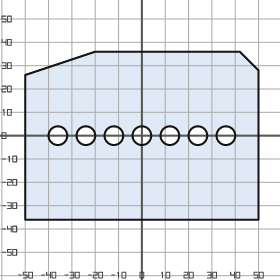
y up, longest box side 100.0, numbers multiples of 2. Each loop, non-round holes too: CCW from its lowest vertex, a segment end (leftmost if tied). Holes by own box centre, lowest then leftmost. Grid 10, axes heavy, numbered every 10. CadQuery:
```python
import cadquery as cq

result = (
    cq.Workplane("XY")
    .moveTo(-50.0, -36.0)
    .lineTo(50.0, -36.0)
    .lineTo(50.0, 28.0)
    .lineTo(42.0, 36.0)
    .lineTo(-20.0, 36.0)
    .lineTo(-50.0, 26.0)
    .close()
    .moveTo(-36.0, 0.0)
    .circle(4.0)
    .moveTo(-24.0, 0.0)
    .circle(4.0)
    .moveTo(-12.0, 0.0)
    .circle(4.0)
    .moveTo(0.0, 0.0)
    .circle(4.0)
    .moveTo(12.0, 0.0)
    .circle(4.0)
    .moveTo(24.0, 0.0)
    .circle(4.0)
    .moveTo(36.0, 0.0)
    .circle(4.0)
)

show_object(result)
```